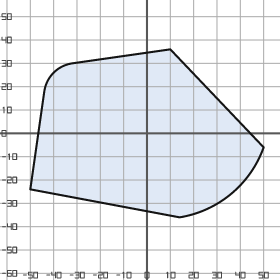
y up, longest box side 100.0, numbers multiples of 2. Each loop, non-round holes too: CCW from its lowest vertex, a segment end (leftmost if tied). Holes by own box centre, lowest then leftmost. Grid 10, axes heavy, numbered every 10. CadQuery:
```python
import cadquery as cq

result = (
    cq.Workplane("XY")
    .moveTo(14.0, -36.0)
    .threePointArc((36.0, -26.0), (50.0, -6.0))
    .lineTo(10.0, 36.0)
    .lineTo(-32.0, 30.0)
    .threePointArc((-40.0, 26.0), (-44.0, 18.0))
    .lineTo(-50.0, -24.0)
    .close()
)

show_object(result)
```